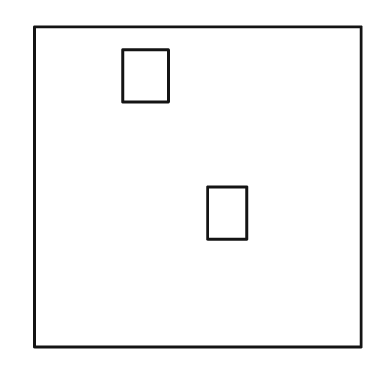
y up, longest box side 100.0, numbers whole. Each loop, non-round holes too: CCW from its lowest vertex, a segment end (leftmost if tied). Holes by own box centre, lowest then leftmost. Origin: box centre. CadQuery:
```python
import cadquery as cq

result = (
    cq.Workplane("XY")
    .moveTo(-50.0, -49.0)
    .lineTo(50.0, -49.0)
    .lineTo(50.0, 49.0)
    .lineTo(-50.0, 49.0)
    .close()
    .moveTo(3.0, -16.0)
    .lineTo(15.0, -16.0)
    .lineTo(15.0, 0.0)
    .lineTo(3.0, 0.0)
    .close()
    .moveTo(-23.0, 26.0)
    .lineTo(-9.0, 26.0)
    .lineTo(-9.0, 42.0)
    .lineTo(-23.0, 42.0)
    .close()
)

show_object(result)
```